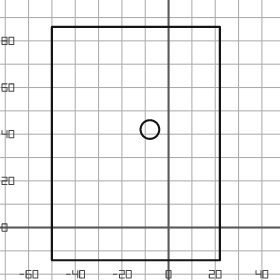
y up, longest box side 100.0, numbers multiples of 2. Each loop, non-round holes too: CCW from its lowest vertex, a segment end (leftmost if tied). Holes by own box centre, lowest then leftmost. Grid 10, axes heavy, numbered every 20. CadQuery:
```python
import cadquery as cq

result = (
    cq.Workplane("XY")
    .moveTo(-50.0, -14.0)
    .lineTo(22.0, -14.0)
    .lineTo(22.0, 86.0)
    .lineTo(-50.0, 86.0)
    .close()
    .moveTo(-8.0, 42.0)
    .circle(4.0)
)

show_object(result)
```